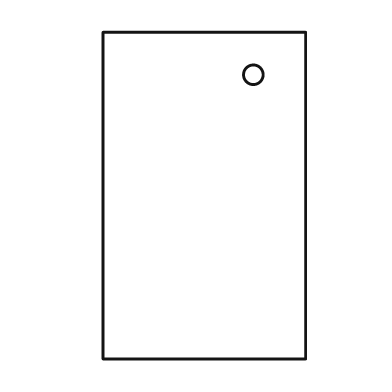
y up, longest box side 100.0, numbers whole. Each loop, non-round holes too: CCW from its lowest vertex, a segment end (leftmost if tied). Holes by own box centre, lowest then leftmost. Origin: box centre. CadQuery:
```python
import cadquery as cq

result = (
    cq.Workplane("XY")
    .moveTo(-31.0, -50.0)
    .lineTo(31.0, -50.0)
    .lineTo(31.0, 50.0)
    .lineTo(-31.0, 50.0)
    .close()
    .moveTo(15.0, 37.0)
    .circle(3.0)
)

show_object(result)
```